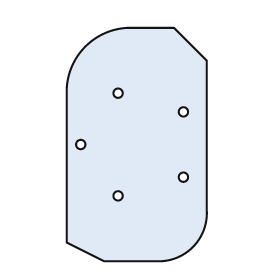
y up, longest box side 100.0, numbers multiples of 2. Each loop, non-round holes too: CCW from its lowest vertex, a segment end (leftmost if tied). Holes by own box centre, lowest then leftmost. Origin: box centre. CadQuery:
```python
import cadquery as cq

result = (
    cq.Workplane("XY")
    .moveTo(-14.0, -50.0)
    .lineTo(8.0, -50.0)
    .threePointArc((24.0, -44.0), (30.0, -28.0))
    .lineTo(30.0, 36.0)
    .lineTo(16.0, 50.0)
    .lineTo(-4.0, 50.0)
    .threePointArc((-22.0, 42.0), (-30.0, 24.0))
    .lineTo(-30.0, -42.0)
    .close()
    .moveTo(-8.0, -22.0)
    .circle(2.0)
    .moveTo(20.0, -14.0)
    .circle(2.0)
    .moveTo(-24.0, 0.0)
    .circle(2.0)
    .moveTo(20.0, 14.0)
    .circle(2.0)
    .moveTo(-8.0, 22.0)
    .circle(2.0)
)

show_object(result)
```